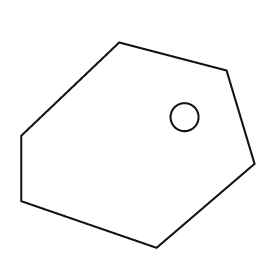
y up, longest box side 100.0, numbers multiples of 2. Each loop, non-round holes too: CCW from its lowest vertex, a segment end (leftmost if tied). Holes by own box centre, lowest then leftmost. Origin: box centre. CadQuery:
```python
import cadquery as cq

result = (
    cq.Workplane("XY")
    .moveTo(8.0, -44.0)
    .lineTo(50.0, -8.0)
    .lineTo(38.0, 32.0)
    .lineTo(-8.0, 44.0)
    .lineTo(-50.0, 4.0)
    .lineTo(-50.0, -24.0)
    .close()
    .moveTo(20.0, 12.0)
    .circle(6.0)
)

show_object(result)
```